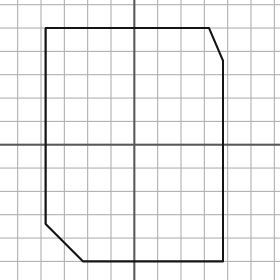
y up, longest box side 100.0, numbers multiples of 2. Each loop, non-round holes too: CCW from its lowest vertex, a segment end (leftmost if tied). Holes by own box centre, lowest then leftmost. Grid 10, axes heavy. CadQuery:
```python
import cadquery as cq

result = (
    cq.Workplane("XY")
    .moveTo(-22.0, -50.0)
    .lineTo(38.0, -50.0)
    .lineTo(38.0, 36.0)
    .lineTo(32.0, 50.0)
    .lineTo(-38.0, 50.0)
    .lineTo(-38.0, -34.0)
    .close()
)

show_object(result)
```